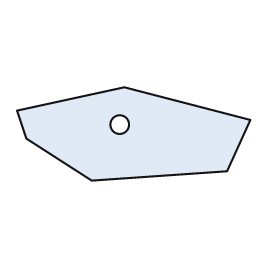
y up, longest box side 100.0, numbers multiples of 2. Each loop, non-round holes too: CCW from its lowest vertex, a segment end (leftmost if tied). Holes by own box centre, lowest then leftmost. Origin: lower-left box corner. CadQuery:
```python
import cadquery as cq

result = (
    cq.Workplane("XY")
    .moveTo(32.0, 0.0)
    .lineTo(90.0, 4.0)
    .lineTo(100.0, 26.0)
    .lineTo(46.0, 40.0)
    .lineTo(0.0, 30.0)
    .lineTo(4.0, 18.0)
    .close()
    .moveTo(44.0, 24.0)
    .circle(4.0)
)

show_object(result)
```